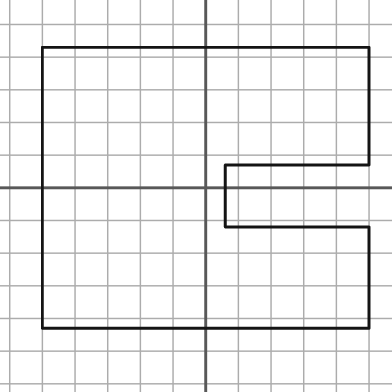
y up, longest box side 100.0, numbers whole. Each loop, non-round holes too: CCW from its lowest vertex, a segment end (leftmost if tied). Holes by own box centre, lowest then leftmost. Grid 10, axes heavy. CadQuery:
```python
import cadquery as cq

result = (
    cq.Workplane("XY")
    .moveTo(-50.0, -43.0)
    .lineTo(50.0, -43.0)
    .lineTo(50.0, -12.0)
    .lineTo(6.0, -12.0)
    .lineTo(6.0, 7.0)
    .lineTo(50.0, 7.0)
    .lineTo(50.0, 43.0)
    .lineTo(-50.0, 43.0)
    .close()
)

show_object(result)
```